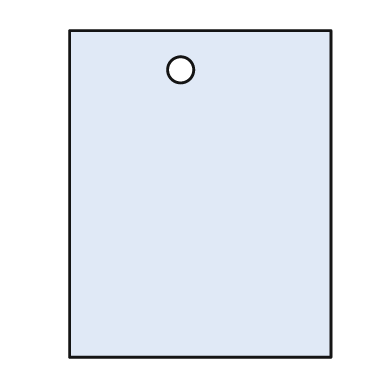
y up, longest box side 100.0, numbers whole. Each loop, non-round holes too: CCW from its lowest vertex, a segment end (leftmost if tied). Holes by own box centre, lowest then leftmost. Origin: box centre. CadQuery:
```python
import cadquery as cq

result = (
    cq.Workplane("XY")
    .moveTo(-40.0, -50.0)
    .lineTo(40.0, -50.0)
    .lineTo(40.0, 50.0)
    .lineTo(-40.0, 50.0)
    .close()
    .moveTo(-6.0, 38.0)
    .circle(4.0)
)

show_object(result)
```